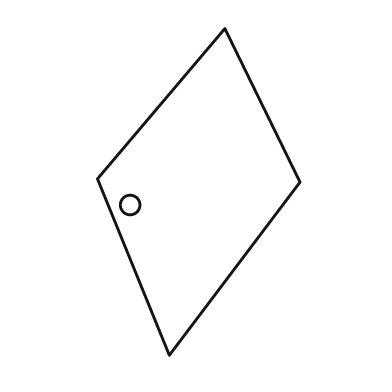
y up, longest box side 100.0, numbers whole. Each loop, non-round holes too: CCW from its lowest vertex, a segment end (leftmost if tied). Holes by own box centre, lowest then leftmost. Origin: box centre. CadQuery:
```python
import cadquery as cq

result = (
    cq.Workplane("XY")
    .moveTo(-9.0, -50.0)
    .lineTo(31.0, 3.0)
    .lineTo(8.0, 50.0)
    .lineTo(-31.0, 4.0)
    .close()
    .moveTo(-21.0, -4.0)
    .circle(3.0)
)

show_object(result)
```